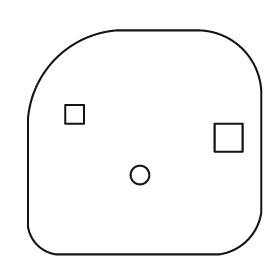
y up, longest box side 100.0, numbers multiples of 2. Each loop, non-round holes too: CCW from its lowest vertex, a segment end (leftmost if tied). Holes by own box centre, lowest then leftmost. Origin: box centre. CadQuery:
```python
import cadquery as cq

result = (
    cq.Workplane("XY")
    .moveTo(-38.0, -48.0)
    .lineTo(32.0, -48.0)
    .threePointArc((44.0, -42.0), (50.0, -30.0))
    .lineTo(50.0, 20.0)
    .threePointArc((42.0, 40.0), (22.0, 48.0))
    .lineTo(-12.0, 48.0)
    .threePointArc((-38.0, 36.0), (-50.0, 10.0))
    .lineTo(-50.0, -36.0)
    .threePointArc((-46.0, -44.0), (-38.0, -48.0))
    .close()
    .moveTo(-2.0, -14.0)
    .circle(4.0)
    .moveTo(30.0, -4.0)
    .lineTo(42.0, -4.0)
    .lineTo(42.0, 8.0)
    .lineTo(30.0, 8.0)
    .close()
    .moveTo(-34.0, 8.0)
    .lineTo(-26.0, 8.0)
    .lineTo(-26.0, 16.0)
    .lineTo(-34.0, 16.0)
    .close()
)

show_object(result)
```